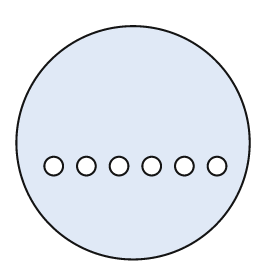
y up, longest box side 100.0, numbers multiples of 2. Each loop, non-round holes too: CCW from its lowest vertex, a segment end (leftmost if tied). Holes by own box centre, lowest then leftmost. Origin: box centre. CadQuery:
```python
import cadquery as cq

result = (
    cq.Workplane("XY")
    .moveTo(0.0, 0.0)
    .circle(50.0)
    .moveTo(-34.0, -10.0)
    .circle(4.0)
    .moveTo(-20.0, -10.0)
    .circle(4.0)
    .moveTo(-6.0, -10.0)
    .circle(4.0)
    .moveTo(8.0, -10.0)
    .circle(4.0)
    .moveTo(22.0, -10.0)
    .circle(4.0)
    .moveTo(36.0, -10.0)
    .circle(4.0)
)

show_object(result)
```